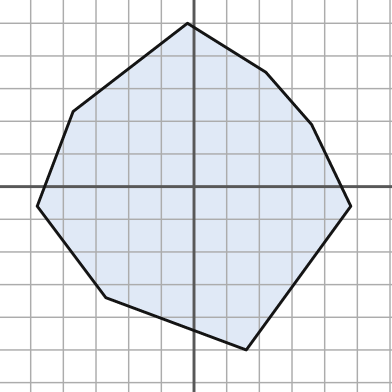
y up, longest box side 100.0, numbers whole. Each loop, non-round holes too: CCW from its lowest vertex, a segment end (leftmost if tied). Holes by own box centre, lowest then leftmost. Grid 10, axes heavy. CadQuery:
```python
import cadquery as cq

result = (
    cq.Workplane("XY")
    .moveTo(16.0, -50.0)
    .lineTo(48.0, -6.0)
    .lineTo(36.0, 19.0)
    .lineTo(22.0, 35.0)
    .lineTo(-2.0, 50.0)
    .lineTo(-37.0, 23.0)
    .lineTo(-48.0, -6.0)
    .lineTo(-27.0, -34.0)
    .close()
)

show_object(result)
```